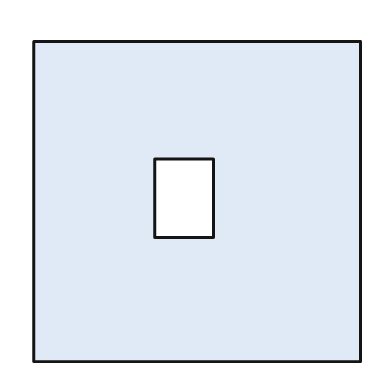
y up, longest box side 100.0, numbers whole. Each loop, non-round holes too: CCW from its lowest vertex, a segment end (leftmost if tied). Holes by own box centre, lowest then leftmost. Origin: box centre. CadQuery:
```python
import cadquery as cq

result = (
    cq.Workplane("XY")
    .moveTo(-50.0, -49.0)
    .lineTo(50.0, -49.0)
    .lineTo(50.0, 49.0)
    .lineTo(-50.0, 49.0)
    .close()
    .moveTo(-13.0, -11.0)
    .lineTo(5.0, -11.0)
    .lineTo(5.0, 13.0)
    .lineTo(-13.0, 13.0)
    .close()
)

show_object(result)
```